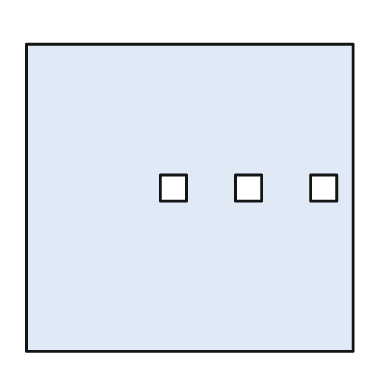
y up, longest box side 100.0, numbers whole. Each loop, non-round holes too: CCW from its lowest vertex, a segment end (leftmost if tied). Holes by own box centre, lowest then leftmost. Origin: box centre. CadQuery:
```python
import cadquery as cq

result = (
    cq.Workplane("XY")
    .moveTo(-50.0, -47.0)
    .lineTo(50.0, -47.0)
    .lineTo(50.0, 47.0)
    .lineTo(-50.0, 47.0)
    .close()
    .moveTo(-9.0, -1.0)
    .lineTo(-1.0, -1.0)
    .lineTo(-1.0, 7.0)
    .lineTo(-9.0, 7.0)
    .close()
    .moveTo(14.0, -1.0)
    .lineTo(22.0, -1.0)
    .lineTo(22.0, 7.0)
    .lineTo(14.0, 7.0)
    .close()
    .moveTo(37.0, -1.0)
    .lineTo(45.0, -1.0)
    .lineTo(45.0, 7.0)
    .lineTo(37.0, 7.0)
    .close()
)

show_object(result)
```